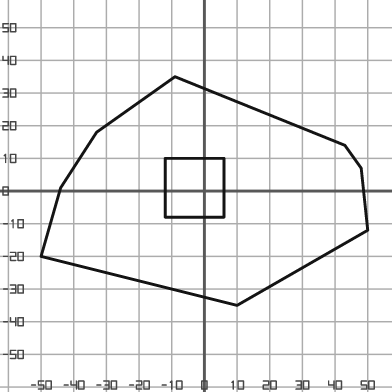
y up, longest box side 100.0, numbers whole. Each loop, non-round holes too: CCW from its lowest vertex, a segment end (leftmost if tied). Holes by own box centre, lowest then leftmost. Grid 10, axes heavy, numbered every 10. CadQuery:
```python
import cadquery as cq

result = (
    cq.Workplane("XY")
    .moveTo(10.0, -35.0)
    .lineTo(50.0, -12.0)
    .lineTo(48.0, 7.0)
    .lineTo(43.0, 14.0)
    .lineTo(-9.0, 35.0)
    .lineTo(-33.0, 18.0)
    .lineTo(-44.0, 1.0)
    .lineTo(-50.0, -20.0)
    .close()
    .moveTo(-12.0, -8.0)
    .lineTo(6.0, -8.0)
    .lineTo(6.0, 10.0)
    .lineTo(-12.0, 10.0)
    .close()
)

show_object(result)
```